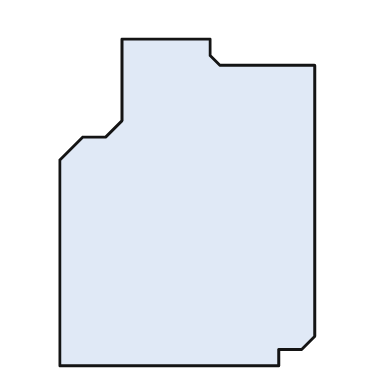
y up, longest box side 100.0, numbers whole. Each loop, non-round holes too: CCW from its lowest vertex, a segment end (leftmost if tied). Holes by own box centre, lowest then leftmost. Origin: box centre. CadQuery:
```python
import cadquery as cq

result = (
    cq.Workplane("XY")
    .moveTo(-39.0, -50.0)
    .lineTo(28.0, -50.0)
    .lineTo(28.0, -45.0)
    .lineTo(35.0, -45.0)
    .lineTo(39.0, -41.0)
    .lineTo(39.0, 42.0)
    .lineTo(10.0, 42.0)
    .lineTo(7.0, 45.0)
    .lineTo(7.0, 50.0)
    .lineTo(-20.0, 50.0)
    .lineTo(-20.0, 25.0)
    .lineTo(-25.0, 20.0)
    .lineTo(-32.0, 20.0)
    .lineTo(-39.0, 13.0)
    .close()
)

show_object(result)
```